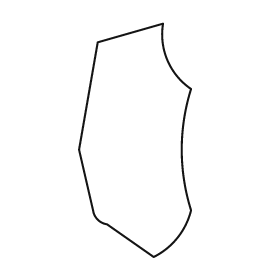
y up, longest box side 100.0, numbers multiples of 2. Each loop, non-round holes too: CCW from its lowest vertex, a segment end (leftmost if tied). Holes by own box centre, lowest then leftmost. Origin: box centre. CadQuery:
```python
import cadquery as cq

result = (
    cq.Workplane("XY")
    .moveTo(8.0, -50.0)
    .threePointArc((18.0, -42.0), (24.0, -30.0))
    .threePointArc((20.0, -4.0), (24.0, 22.0))
    .threePointArc((14.0, 34.0), (12.0, 50.0))
    .lineTo(-16.0, 42.0)
    .lineTo(-24.0, -4.0)
    .lineTo(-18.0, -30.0)
    .threePointArc((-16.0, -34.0), (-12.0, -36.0))
    .close()
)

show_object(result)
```